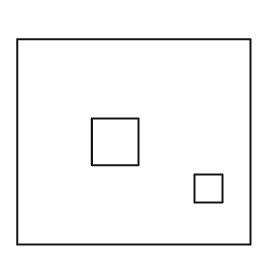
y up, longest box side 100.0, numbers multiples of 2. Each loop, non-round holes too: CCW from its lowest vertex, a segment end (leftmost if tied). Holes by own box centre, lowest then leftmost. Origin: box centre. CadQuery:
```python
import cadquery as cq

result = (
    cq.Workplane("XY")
    .moveTo(-50.0, -44.0)
    .lineTo(50.0, -44.0)
    .lineTo(50.0, 44.0)
    .lineTo(-50.0, 44.0)
    .close()
    .moveTo(26.0, -26.0)
    .lineTo(38.0, -26.0)
    .lineTo(38.0, -14.0)
    .lineTo(26.0, -14.0)
    .close()
    .moveTo(-18.0, -10.0)
    .lineTo(2.0, -10.0)
    .lineTo(2.0, 10.0)
    .lineTo(-18.0, 10.0)
    .close()
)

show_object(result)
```